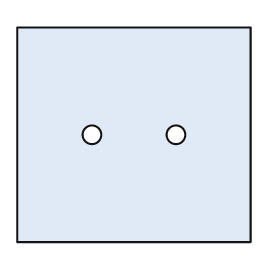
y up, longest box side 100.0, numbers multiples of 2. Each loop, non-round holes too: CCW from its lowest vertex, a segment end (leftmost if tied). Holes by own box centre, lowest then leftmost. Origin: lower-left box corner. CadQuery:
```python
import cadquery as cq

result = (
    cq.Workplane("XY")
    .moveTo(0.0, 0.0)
    .lineTo(100.0, 0.0)
    .lineTo(100.0, 92.0)
    .lineTo(0.0, 92.0)
    .close()
    .moveTo(32.0, 46.0)
    .circle(4.0)
    .moveTo(68.0, 46.0)
    .circle(4.0)
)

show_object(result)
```